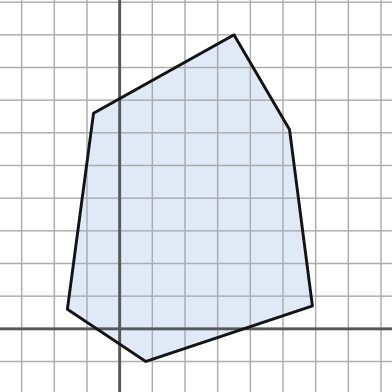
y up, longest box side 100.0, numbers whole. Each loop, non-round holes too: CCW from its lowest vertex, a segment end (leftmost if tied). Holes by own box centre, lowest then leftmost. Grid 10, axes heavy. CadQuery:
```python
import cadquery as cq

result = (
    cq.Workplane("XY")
    .moveTo(8.0, -10.0)
    .lineTo(59.0, 7.0)
    .lineTo(52.0, 61.0)
    .lineTo(35.0, 90.0)
    .lineTo(-8.0, 66.0)
    .lineTo(-16.0, 6.0)
    .close()
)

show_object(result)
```